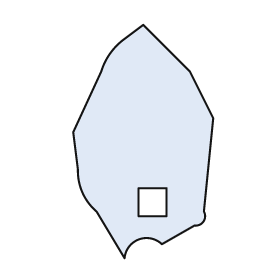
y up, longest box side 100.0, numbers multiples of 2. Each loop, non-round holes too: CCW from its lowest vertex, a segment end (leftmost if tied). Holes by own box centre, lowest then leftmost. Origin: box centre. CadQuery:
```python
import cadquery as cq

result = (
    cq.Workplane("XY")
    .moveTo(-8.0, -50.0)
    .threePointArc((-2.0, -42.0), (8.0, -44.0))
    .lineTo(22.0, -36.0)
    .threePointArc((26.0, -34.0), (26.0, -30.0))
    .lineTo(30.0, 10.0)
    .lineTo(20.0, 30.0)
    .lineTo(0.0, 50.0)
    .lineTo(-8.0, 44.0)
    .threePointArc((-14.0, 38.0), (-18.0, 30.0))
    .lineTo(-30.0, 4.0)
    .lineTo(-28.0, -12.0)
    .threePointArc((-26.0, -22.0), (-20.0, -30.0))
    .close()
    .moveTo(-2.0, -32.0)
    .lineTo(10.0, -32.0)
    .lineTo(10.0, -20.0)
    .lineTo(-2.0, -20.0)
    .close()
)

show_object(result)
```